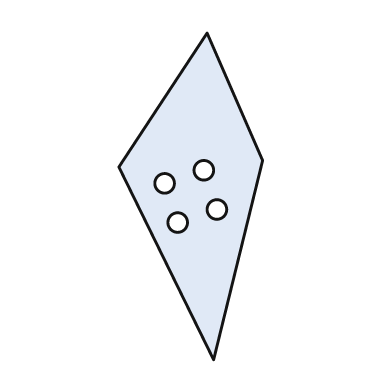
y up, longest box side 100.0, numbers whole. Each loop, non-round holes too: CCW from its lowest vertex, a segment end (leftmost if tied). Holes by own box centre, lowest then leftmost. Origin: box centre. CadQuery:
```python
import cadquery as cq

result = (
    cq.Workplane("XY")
    .moveTo(7.0, -50.0)
    .lineTo(22.0, 11.0)
    .lineTo(5.0, 50.0)
    .lineTo(-22.0, 9.0)
    .close()
    .moveTo(-4.0, -8.0)
    .circle(3.0)
    .moveTo(8.0, -4.0)
    .circle(3.0)
    .moveTo(-8.0, 4.0)
    .circle(3.0)
    .moveTo(4.0, 8.0)
    .circle(3.0)
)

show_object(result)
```